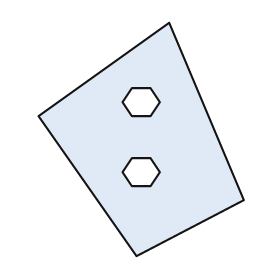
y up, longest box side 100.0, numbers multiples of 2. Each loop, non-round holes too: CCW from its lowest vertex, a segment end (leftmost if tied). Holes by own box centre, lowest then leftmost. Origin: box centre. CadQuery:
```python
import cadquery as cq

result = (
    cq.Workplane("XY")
    .moveTo(-2.0, -50.0)
    .lineTo(44.0, -26.0)
    .lineTo(12.0, 50.0)
    .lineTo(-44.0, 10.0)
    .close()
    .moveTo(-4.0, -20.0)
    .lineTo(4.0, -20.0)
    .lineTo(8.0, -14.0)
    .lineTo(4.0, -8.0)
    .lineTo(-4.0, -8.0)
    .lineTo(-8.0, -14.0)
    .close()
    .moveTo(-4.0, 10.0)
    .lineTo(4.0, 10.0)
    .lineTo(8.0, 16.0)
    .lineTo(4.0, 22.0)
    .lineTo(-4.0, 22.0)
    .lineTo(-8.0, 16.0)
    .close()
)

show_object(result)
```